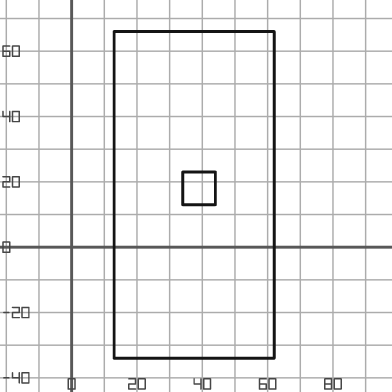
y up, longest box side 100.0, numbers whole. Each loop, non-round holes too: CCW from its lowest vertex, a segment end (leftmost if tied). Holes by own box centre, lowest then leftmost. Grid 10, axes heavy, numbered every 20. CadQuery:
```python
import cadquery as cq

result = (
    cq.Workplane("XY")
    .moveTo(13.0, -34.0)
    .lineTo(62.0, -34.0)
    .lineTo(62.0, 66.0)
    .lineTo(13.0, 66.0)
    .close()
    .moveTo(34.0, 13.0)
    .lineTo(44.0, 13.0)
    .lineTo(44.0, 23.0)
    .lineTo(34.0, 23.0)
    .close()
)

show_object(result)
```